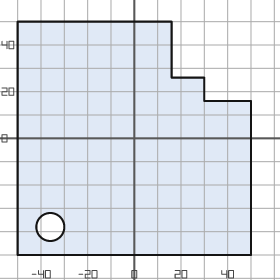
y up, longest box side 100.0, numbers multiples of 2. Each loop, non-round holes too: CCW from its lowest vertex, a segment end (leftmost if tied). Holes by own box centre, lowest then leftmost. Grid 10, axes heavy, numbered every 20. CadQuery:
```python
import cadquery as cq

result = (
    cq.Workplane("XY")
    .moveTo(-50.0, -50.0)
    .lineTo(50.0, -50.0)
    .lineTo(50.0, 16.0)
    .lineTo(30.0, 16.0)
    .lineTo(30.0, 26.0)
    .lineTo(16.0, 26.0)
    .lineTo(16.0, 50.0)
    .lineTo(-50.0, 50.0)
    .close()
    .moveTo(-36.0, -38.0)
    .circle(6.0)
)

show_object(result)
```